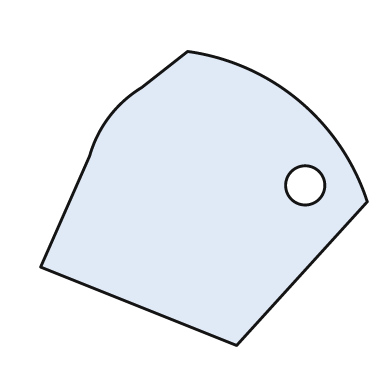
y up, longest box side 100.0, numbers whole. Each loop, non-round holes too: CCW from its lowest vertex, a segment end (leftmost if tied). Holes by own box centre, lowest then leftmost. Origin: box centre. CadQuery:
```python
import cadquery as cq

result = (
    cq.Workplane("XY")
    .moveTo(10.0, -45.0)
    .lineTo(50.0, -1.0)
    .threePointArc((29.0, 30.0), (-5.0, 45.0))
    .lineTo(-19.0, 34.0)
    .threePointArc((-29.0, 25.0), (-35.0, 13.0))
    .lineTo(-50.0, -21.0)
    .close()
    .moveTo(31.0, 4.0)
    .circle(6.0)
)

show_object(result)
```